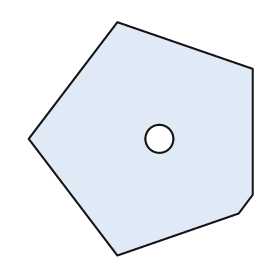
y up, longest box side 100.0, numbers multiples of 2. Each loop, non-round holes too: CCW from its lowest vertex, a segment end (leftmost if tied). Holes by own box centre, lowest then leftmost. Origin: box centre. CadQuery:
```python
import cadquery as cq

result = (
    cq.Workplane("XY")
    .moveTo(-10.0, -50.0)
    .lineTo(42.0, -32.0)
    .lineTo(48.0, -24.0)
    .lineTo(48.0, 30.0)
    .lineTo(-10.0, 50.0)
    .lineTo(-48.0, 0.0)
    .close()
    .moveTo(8.0, 0.0)
    .circle(6.0)
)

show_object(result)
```